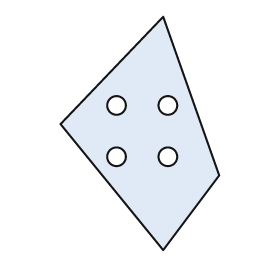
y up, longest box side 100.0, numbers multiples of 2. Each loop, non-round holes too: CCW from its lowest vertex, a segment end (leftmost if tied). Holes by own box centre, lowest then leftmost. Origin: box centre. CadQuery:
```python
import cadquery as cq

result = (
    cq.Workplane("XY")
    .moveTo(10.0, -50.0)
    .lineTo(34.0, -18.0)
    .lineTo(10.0, 50.0)
    .lineTo(-34.0, 4.0)
    .close()
    .moveTo(-10.0, -10.0)
    .circle(4.0)
    .moveTo(12.0, -10.0)
    .circle(4.0)
    .moveTo(-10.0, 12.0)
    .circle(4.0)
    .moveTo(12.0, 12.0)
    .circle(4.0)
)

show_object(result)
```